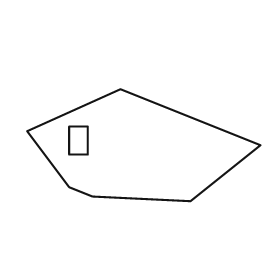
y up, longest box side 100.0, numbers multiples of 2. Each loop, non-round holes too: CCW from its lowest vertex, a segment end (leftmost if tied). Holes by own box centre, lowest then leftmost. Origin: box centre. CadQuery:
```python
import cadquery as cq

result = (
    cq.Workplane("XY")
    .moveTo(20.0, -24.0)
    .lineTo(50.0, 0.0)
    .lineTo(-10.0, 24.0)
    .lineTo(-50.0, 6.0)
    .lineTo(-32.0, -18.0)
    .lineTo(-22.0, -22.0)
    .close()
    .moveTo(-32.0, -4.0)
    .lineTo(-24.0, -4.0)
    .lineTo(-24.0, 8.0)
    .lineTo(-32.0, 8.0)
    .close()
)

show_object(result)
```